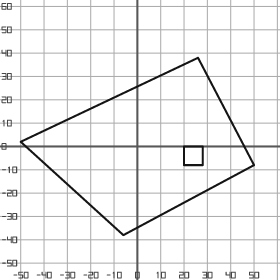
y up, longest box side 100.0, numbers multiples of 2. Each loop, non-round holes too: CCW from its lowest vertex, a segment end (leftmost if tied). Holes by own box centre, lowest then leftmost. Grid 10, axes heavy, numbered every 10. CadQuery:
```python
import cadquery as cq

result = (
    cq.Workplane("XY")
    .moveTo(-6.0, -38.0)
    .lineTo(50.0, -8.0)
    .lineTo(26.0, 38.0)
    .lineTo(-50.0, 2.0)
    .close()
    .moveTo(20.0, -8.0)
    .lineTo(28.0, -8.0)
    .lineTo(28.0, 0.0)
    .lineTo(20.0, 0.0)
    .close()
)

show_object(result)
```